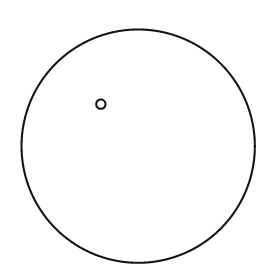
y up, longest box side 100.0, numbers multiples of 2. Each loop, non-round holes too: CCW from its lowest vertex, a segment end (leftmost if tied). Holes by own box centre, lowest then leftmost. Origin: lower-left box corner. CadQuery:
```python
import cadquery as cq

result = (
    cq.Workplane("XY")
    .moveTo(50.0, 50.0)
    .circle(50.0)
    .moveTo(34.0, 68.0)
    .circle(2.0)
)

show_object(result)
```